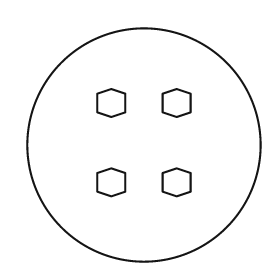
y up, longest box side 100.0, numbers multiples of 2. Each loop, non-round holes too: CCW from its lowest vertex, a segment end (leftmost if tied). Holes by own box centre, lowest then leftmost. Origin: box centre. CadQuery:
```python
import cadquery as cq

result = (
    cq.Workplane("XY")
    .moveTo(0.0, 0.0)
    .circle(50.0)
    .moveTo(-14.0, -22.0)
    .lineTo(-8.0, -20.0)
    .lineTo(-8.0, -12.0)
    .lineTo(-14.0, -10.0)
    .lineTo(-20.0, -12.0)
    .lineTo(-20.0, -20.0)
    .close()
    .moveTo(14.0, -22.0)
    .lineTo(20.0, -20.0)
    .lineTo(20.0, -12.0)
    .lineTo(14.0, -10.0)
    .lineTo(8.0, -12.0)
    .lineTo(8.0, -20.0)
    .close()
    .moveTo(-14.0, 12.0)
    .lineTo(-8.0, 14.0)
    .lineTo(-8.0, 22.0)
    .lineTo(-14.0, 24.0)
    .lineTo(-20.0, 22.0)
    .lineTo(-20.0, 14.0)
    .close()
    .moveTo(14.0, 12.0)
    .lineTo(20.0, 14.0)
    .lineTo(20.0, 22.0)
    .lineTo(14.0, 24.0)
    .lineTo(8.0, 22.0)
    .lineTo(8.0, 14.0)
    .close()
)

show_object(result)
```